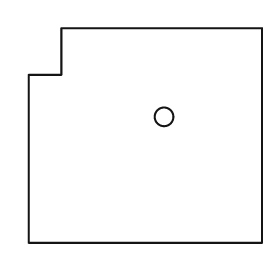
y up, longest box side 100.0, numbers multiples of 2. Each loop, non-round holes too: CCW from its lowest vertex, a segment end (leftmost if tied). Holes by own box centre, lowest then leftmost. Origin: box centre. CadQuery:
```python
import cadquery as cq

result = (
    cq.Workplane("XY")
    .moveTo(-50.0, -46.0)
    .lineTo(50.0, -46.0)
    .lineTo(50.0, 46.0)
    .lineTo(-36.0, 46.0)
    .lineTo(-36.0, 26.0)
    .lineTo(-50.0, 26.0)
    .close()
    .moveTo(8.0, 8.0)
    .circle(4.0)
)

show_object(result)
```